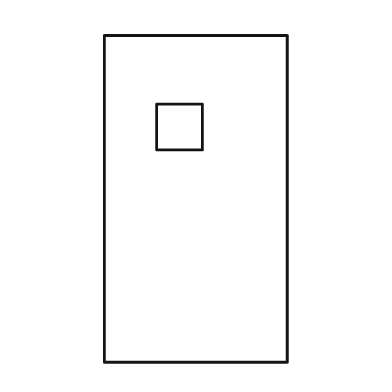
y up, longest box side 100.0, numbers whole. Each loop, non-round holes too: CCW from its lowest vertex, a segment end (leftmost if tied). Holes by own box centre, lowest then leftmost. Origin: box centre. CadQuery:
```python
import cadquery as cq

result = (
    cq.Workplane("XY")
    .moveTo(-28.0, -50.0)
    .lineTo(28.0, -50.0)
    .lineTo(28.0, 50.0)
    .lineTo(-28.0, 50.0)
    .close()
    .moveTo(-12.0, 15.0)
    .lineTo(2.0, 15.0)
    .lineTo(2.0, 29.0)
    .lineTo(-12.0, 29.0)
    .close()
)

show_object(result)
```